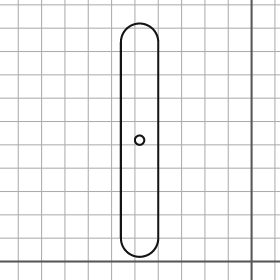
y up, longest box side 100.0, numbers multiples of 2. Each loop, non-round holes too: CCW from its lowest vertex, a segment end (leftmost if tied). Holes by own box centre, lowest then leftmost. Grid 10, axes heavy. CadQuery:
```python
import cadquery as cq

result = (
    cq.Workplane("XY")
    .moveTo(-56.0, 10.0)
    .threePointArc((-48.0, 2.0), (-40.0, 10.0))
    .lineTo(-40.0, 94.0)
    .threePointArc((-48.0, 102.0), (-56.0, 94.0))
    .close()
    .moveTo(-48.0, 52.0)
    .circle(2.0)
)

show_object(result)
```